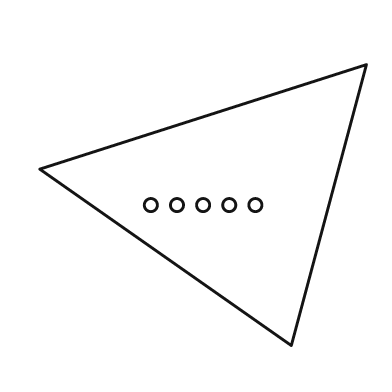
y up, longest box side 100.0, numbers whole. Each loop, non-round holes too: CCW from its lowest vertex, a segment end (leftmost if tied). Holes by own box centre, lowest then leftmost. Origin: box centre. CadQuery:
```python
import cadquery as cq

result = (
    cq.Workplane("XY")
    .moveTo(27.0, -43.0)
    .lineTo(50.0, 43.0)
    .lineTo(-50.0, 11.0)
    .close()
    .moveTo(-16.0, 0.0)
    .circle(2.0)
    .moveTo(-8.0, 0.0)
    .circle(2.0)
    .moveTo(0.0, 0.0)
    .circle(2.0)
    .moveTo(8.0, 0.0)
    .circle(2.0)
    .moveTo(16.0, 0.0)
    .circle(2.0)
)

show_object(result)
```